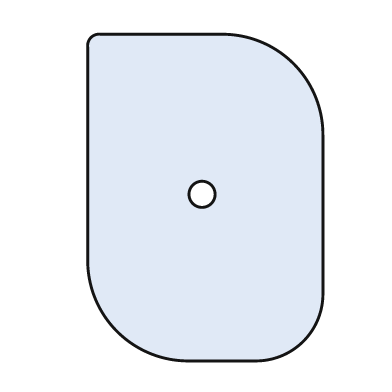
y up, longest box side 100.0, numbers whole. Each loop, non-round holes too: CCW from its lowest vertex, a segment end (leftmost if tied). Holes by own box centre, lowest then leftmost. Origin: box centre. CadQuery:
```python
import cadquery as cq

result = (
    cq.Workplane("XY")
    .moveTo(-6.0, -50.0)
    .lineTo(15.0, -50.0)
    .threePointArc((30.0, -44.0), (36.0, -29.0))
    .lineTo(36.0, 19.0)
    .threePointArc((27.0, 41.0), (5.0, 50.0))
    .lineTo(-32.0, 50.0)
    .threePointArc((-35.0, 49.0), (-36.0, 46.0))
    .lineTo(-36.0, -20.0)
    .threePointArc((-27.0, -41.0), (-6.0, -50.0))
    .close()
    .moveTo(-1.0, 1.0)
    .circle(4.0)
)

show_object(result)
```